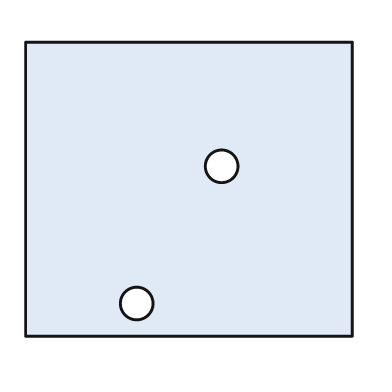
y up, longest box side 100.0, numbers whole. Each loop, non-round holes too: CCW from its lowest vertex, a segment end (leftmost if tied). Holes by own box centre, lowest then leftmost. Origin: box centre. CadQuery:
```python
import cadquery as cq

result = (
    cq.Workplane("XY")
    .moveTo(-50.0, -45.0)
    .lineTo(50.0, -45.0)
    .lineTo(50.0, 45.0)
    .lineTo(-50.0, 45.0)
    .close()
    .moveTo(-16.0, -35.0)
    .circle(5.0)
    .moveTo(10.0, 7.0)
    .circle(5.0)
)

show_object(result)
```